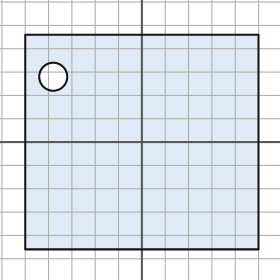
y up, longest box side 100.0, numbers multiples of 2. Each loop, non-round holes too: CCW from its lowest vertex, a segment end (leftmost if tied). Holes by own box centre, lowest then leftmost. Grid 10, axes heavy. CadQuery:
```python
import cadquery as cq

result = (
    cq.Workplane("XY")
    .moveTo(-50.0, -46.0)
    .lineTo(50.0, -46.0)
    .lineTo(50.0, 46.0)
    .lineTo(-50.0, 46.0)
    .close()
    .moveTo(-38.0, 28.0)
    .circle(6.0)
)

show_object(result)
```